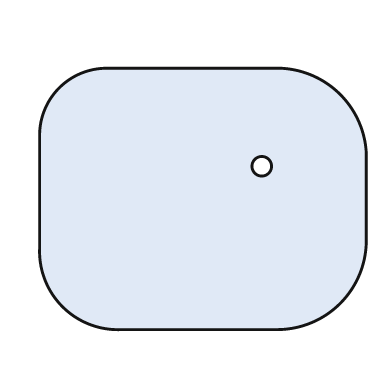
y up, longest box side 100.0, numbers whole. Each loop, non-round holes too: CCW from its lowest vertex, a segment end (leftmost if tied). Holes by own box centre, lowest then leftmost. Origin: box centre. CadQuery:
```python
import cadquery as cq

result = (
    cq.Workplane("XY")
    .moveTo(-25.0, -40.0)
    .lineTo(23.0, -40.0)
    .threePointArc((42.0, -32.0), (50.0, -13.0))
    .lineTo(50.0, 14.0)
    .threePointArc((42.0, 32.0), (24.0, 40.0))
    .lineTo(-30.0, 40.0)
    .threePointArc((-44.0, 34.0), (-50.0, 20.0))
    .lineTo(-50.0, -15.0)
    .threePointArc((-43.0, -33.0), (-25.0, -40.0))
    .close()
    .moveTo(18.0, 10.0)
    .circle(3.0)
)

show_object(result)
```